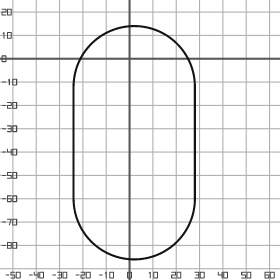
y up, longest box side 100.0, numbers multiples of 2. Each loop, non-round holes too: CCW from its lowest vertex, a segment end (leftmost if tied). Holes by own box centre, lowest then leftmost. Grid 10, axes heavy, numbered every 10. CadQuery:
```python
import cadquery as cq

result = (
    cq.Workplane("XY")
    .moveTo(-24.0, -60.0)
    .threePointArc((2.0, -86.0), (28.0, -60.0))
    .lineTo(28.0, -12.0)
    .threePointArc((2.0, 14.0), (-24.0, -12.0))
    .close()
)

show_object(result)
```